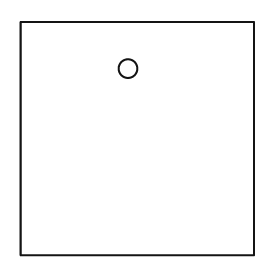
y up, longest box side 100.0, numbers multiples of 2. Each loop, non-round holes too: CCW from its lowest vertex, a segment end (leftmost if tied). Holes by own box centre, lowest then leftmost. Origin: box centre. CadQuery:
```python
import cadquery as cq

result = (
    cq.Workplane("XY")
    .moveTo(-50.0, -50.0)
    .lineTo(50.0, -50.0)
    .lineTo(50.0, 50.0)
    .lineTo(-50.0, 50.0)
    .close()
    .moveTo(-4.0, 30.0)
    .circle(4.0)
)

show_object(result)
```